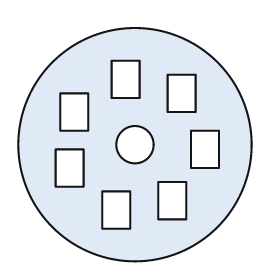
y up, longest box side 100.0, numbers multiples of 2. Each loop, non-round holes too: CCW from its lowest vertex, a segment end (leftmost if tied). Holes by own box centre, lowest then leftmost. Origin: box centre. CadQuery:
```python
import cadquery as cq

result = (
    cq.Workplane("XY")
    .moveTo(0.0, 0.0)
    .circle(50.0)
    .moveTo(-14.0, -36.0)
    .lineTo(-2.0, -36.0)
    .lineTo(-2.0, -20.0)
    .lineTo(-14.0, -20.0)
    .close()
    .moveTo(10.0, -32.0)
    .lineTo(22.0, -32.0)
    .lineTo(22.0, -16.0)
    .lineTo(10.0, -16.0)
    .close()
    .moveTo(-34.0, -18.0)
    .lineTo(-22.0, -18.0)
    .lineTo(-22.0, -2.0)
    .lineTo(-34.0, -2.0)
    .close()
    .moveTo(24.0, -10.0)
    .lineTo(36.0, -10.0)
    .lineTo(36.0, 6.0)
    .lineTo(24.0, 6.0)
    .close()
    .moveTo(0.0, 0.0)
    .circle(8.0)
    .moveTo(-32.0, 6.0)
    .lineTo(-20.0, 6.0)
    .lineTo(-20.0, 22.0)
    .lineTo(-32.0, 22.0)
    .close()
    .moveTo(14.0, 14.0)
    .lineTo(26.0, 14.0)
    .lineTo(26.0, 30.0)
    .lineTo(14.0, 30.0)
    .close()
    .moveTo(-10.0, 20.0)
    .lineTo(2.0, 20.0)
    .lineTo(2.0, 36.0)
    .lineTo(-10.0, 36.0)
    .close()
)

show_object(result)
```